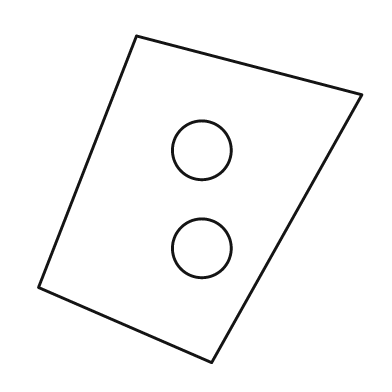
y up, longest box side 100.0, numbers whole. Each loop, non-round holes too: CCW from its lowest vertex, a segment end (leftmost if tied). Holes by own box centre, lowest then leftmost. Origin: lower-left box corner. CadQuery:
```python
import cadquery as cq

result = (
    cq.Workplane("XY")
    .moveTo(53.0, 0.0)
    .lineTo(99.0, 82.0)
    .lineTo(30.0, 100.0)
    .lineTo(0.0, 23.0)
    .close()
    .moveTo(50.0, 35.0)
    .circle(9.0)
    .moveTo(50.0, 65.0)
    .circle(9.0)
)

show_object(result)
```